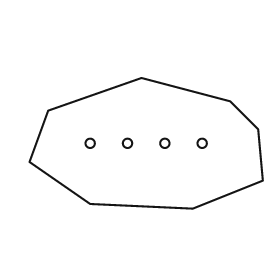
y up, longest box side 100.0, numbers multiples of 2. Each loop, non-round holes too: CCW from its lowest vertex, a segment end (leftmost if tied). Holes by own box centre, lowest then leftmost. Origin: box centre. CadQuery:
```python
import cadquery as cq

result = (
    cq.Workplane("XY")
    .moveTo(20.0, -28.0)
    .lineTo(50.0, -16.0)
    .lineTo(48.0, 6.0)
    .lineTo(36.0, 18.0)
    .lineTo(-2.0, 28.0)
    .lineTo(-42.0, 14.0)
    .lineTo(-50.0, -8.0)
    .lineTo(-24.0, -26.0)
    .close()
    .moveTo(-24.0, 0.0)
    .circle(2.0)
    .moveTo(-8.0, 0.0)
    .circle(2.0)
    .moveTo(8.0, 0.0)
    .circle(2.0)
    .moveTo(24.0, 0.0)
    .circle(2.0)
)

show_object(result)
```